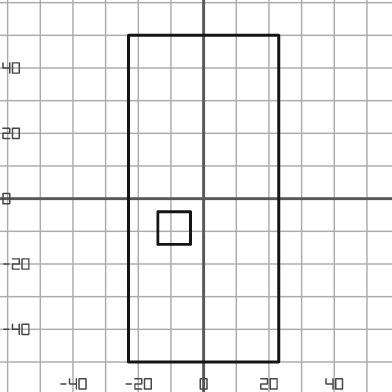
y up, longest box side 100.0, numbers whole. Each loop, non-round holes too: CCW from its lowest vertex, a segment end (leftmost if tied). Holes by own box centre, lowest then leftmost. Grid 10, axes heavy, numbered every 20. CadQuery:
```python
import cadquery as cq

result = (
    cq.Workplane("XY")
    .moveTo(-23.0, -50.0)
    .lineTo(23.0, -50.0)
    .lineTo(23.0, 50.0)
    .lineTo(-23.0, 50.0)
    .close()
    .moveTo(-14.0, -14.0)
    .lineTo(-4.0, -14.0)
    .lineTo(-4.0, -4.0)
    .lineTo(-14.0, -4.0)
    .close()
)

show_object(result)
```